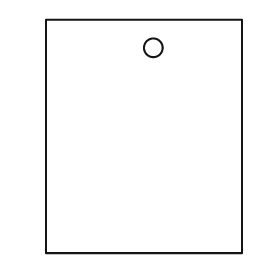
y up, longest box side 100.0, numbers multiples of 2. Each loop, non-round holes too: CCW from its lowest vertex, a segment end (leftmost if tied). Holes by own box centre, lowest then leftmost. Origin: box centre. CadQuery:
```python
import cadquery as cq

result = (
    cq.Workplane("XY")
    .moveTo(-42.0, -50.0)
    .lineTo(42.0, -50.0)
    .lineTo(42.0, 50.0)
    .lineTo(-42.0, 50.0)
    .close()
    .moveTo(4.0, 38.0)
    .circle(4.0)
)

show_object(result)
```